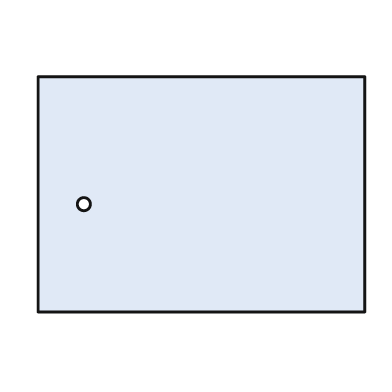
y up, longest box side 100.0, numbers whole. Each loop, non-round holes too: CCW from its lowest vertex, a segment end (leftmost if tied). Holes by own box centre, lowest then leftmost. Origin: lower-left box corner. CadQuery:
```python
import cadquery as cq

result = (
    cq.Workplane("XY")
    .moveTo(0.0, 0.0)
    .lineTo(100.0, 0.0)
    .lineTo(100.0, 72.0)
    .lineTo(0.0, 72.0)
    .close()
    .moveTo(14.0, 33.0)
    .circle(2.0)
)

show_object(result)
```